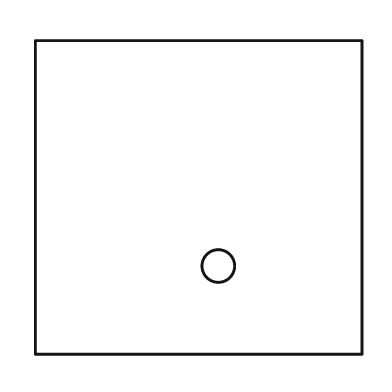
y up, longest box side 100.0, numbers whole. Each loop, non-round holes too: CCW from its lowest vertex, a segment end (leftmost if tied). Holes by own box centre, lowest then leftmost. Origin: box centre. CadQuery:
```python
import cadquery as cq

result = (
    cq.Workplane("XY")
    .moveTo(-50.0, -48.0)
    .lineTo(50.0, -48.0)
    .lineTo(50.0, 48.0)
    .lineTo(-50.0, 48.0)
    .close()
    .moveTo(6.0, -21.0)
    .circle(5.0)
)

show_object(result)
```